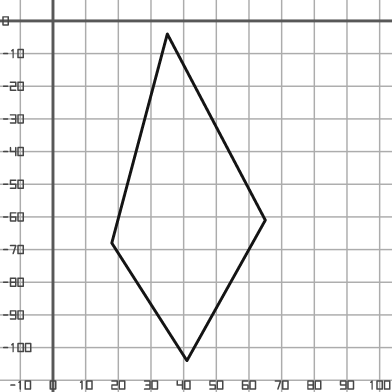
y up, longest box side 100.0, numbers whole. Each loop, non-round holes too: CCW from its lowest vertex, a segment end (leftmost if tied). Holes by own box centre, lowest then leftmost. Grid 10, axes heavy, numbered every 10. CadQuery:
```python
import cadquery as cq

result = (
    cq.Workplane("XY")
    .moveTo(41.0, -104.0)
    .lineTo(65.0, -61.0)
    .lineTo(35.0, -4.0)
    .lineTo(18.0, -68.0)
    .close()
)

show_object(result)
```